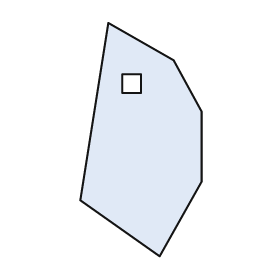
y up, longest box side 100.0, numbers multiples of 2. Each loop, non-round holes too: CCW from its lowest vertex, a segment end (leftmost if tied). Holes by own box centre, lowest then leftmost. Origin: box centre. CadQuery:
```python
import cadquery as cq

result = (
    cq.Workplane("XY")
    .moveTo(8.0, -50.0)
    .lineTo(26.0, -18.0)
    .lineTo(26.0, 12.0)
    .lineTo(14.0, 34.0)
    .lineTo(-14.0, 50.0)
    .lineTo(-26.0, -26.0)
    .close()
    .moveTo(-8.0, 20.0)
    .lineTo(0.0, 20.0)
    .lineTo(0.0, 28.0)
    .lineTo(-8.0, 28.0)
    .close()
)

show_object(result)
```